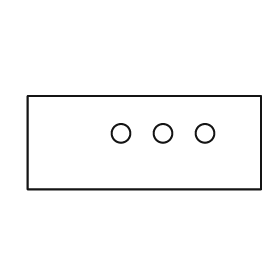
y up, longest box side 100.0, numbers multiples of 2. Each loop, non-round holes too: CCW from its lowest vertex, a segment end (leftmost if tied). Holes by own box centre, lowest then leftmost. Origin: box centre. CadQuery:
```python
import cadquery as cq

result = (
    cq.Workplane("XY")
    .moveTo(-50.0, -20.0)
    .lineTo(50.0, -20.0)
    .lineTo(50.0, 20.0)
    .lineTo(-50.0, 20.0)
    .close()
    .moveTo(-10.0, 4.0)
    .circle(4.0)
    .moveTo(8.0, 4.0)
    .circle(4.0)
    .moveTo(26.0, 4.0)
    .circle(4.0)
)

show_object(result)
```